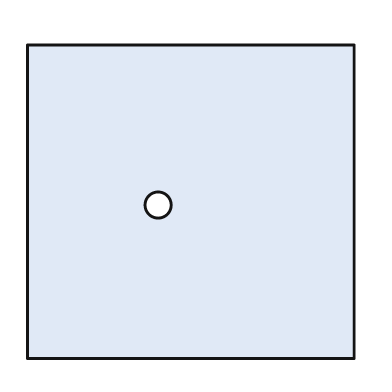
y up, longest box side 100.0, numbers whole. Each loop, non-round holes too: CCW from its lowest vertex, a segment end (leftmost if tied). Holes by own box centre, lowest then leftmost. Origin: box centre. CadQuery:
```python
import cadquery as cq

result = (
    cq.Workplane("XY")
    .moveTo(-50.0, -48.0)
    .lineTo(50.0, -48.0)
    .lineTo(50.0, 48.0)
    .lineTo(-50.0, 48.0)
    .close()
    .moveTo(-10.0, -1.0)
    .circle(4.0)
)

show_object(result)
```